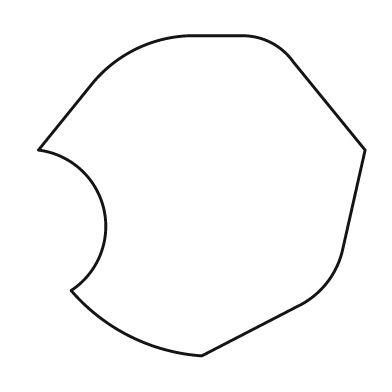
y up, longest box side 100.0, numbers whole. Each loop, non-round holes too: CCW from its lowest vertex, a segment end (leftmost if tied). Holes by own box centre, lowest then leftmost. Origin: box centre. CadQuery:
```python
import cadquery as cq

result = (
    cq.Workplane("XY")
    .moveTo(0.0, -49.0)
    .lineTo(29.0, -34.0)
    .threePointArc((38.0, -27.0), (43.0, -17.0))
    .lineTo(50.0, 14.0)
    .lineTo(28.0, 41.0)
    .threePointArc((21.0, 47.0), (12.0, 49.0))
    .lineTo(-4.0, 49.0)
    .threePointArc((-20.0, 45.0), (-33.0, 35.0))
    .lineTo(-50.0, 14.0)
    .threePointArc((-30.0, -4.0), (-40.0, -29.0))
    .threePointArc((-22.0, -43.0), (0.0, -49.0))
    .close()
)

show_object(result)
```